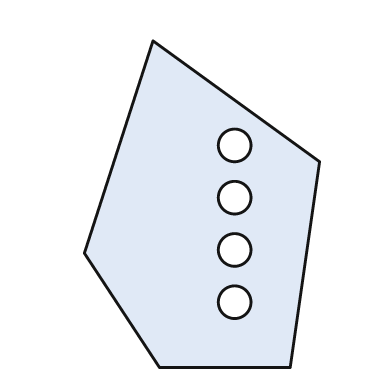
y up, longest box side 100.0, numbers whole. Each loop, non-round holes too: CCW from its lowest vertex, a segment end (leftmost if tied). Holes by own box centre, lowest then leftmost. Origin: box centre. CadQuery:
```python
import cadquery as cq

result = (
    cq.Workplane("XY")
    .moveTo(-13.0, -50.0)
    .lineTo(27.0, -50.0)
    .lineTo(36.0, 13.0)
    .lineTo(-15.0, 50.0)
    .lineTo(-36.0, -15.0)
    .close()
    .moveTo(10.0, -30.0)
    .circle(5.0)
    .moveTo(10.0, -14.0)
    .circle(5.0)
    .moveTo(10.0, 2.0)
    .circle(5.0)
    .moveTo(10.0, 18.0)
    .circle(5.0)
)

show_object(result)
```